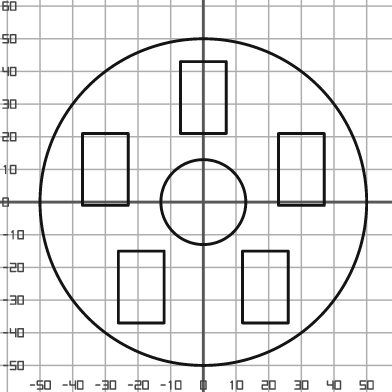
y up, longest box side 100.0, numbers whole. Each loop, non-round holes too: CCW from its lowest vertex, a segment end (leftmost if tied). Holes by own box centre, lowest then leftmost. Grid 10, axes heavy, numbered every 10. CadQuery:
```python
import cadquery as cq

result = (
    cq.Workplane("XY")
    .moveTo(0.0, 0.0)
    .circle(50.0)
    .moveTo(-26.0, -37.0)
    .lineTo(-12.0, -37.0)
    .lineTo(-12.0, -15.0)
    .lineTo(-26.0, -15.0)
    .close()
    .moveTo(12.0, -37.0)
    .lineTo(26.0, -37.0)
    .lineTo(26.0, -15.0)
    .lineTo(12.0, -15.0)
    .close()
    .moveTo(0.0, 0.0)
    .circle(13.0)
    .moveTo(-37.0, -1.0)
    .lineTo(-23.0, -1.0)
    .lineTo(-23.0, 21.0)
    .lineTo(-37.0, 21.0)
    .close()
    .moveTo(23.0, -1.0)
    .lineTo(37.0, -1.0)
    .lineTo(37.0, 21.0)
    .lineTo(23.0, 21.0)
    .close()
    .moveTo(-7.0, 21.0)
    .lineTo(7.0, 21.0)
    .lineTo(7.0, 43.0)
    .lineTo(-7.0, 43.0)
    .close()
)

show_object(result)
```